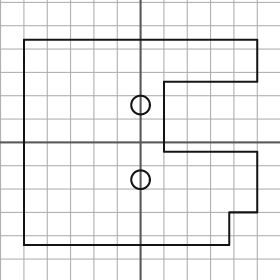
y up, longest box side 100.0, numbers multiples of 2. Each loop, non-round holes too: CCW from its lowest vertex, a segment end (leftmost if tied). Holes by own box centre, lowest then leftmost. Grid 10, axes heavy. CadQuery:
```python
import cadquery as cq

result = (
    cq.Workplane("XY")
    .moveTo(-50.0, -44.0)
    .lineTo(38.0, -44.0)
    .lineTo(38.0, -30.0)
    .lineTo(50.0, -30.0)
    .lineTo(50.0, -4.0)
    .lineTo(10.0, -4.0)
    .lineTo(10.0, 26.0)
    .lineTo(50.0, 26.0)
    .lineTo(50.0, 44.0)
    .lineTo(-50.0, 44.0)
    .close()
    .moveTo(0.0, -16.0)
    .circle(4.0)
    .moveTo(0.0, 16.0)
    .circle(4.0)
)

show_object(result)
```